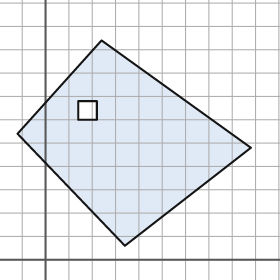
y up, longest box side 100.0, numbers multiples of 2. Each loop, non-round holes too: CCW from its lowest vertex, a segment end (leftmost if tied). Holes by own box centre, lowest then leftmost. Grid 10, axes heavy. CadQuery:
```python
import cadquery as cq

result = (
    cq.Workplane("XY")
    .moveTo(34.0, 6.0)
    .lineTo(88.0, 48.0)
    .lineTo(24.0, 94.0)
    .lineTo(-12.0, 54.0)
    .close()
    .moveTo(14.0, 60.0)
    .lineTo(22.0, 60.0)
    .lineTo(22.0, 68.0)
    .lineTo(14.0, 68.0)
    .close()
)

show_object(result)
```